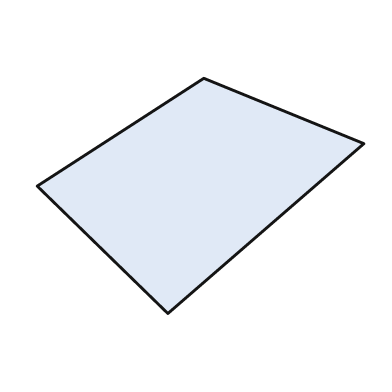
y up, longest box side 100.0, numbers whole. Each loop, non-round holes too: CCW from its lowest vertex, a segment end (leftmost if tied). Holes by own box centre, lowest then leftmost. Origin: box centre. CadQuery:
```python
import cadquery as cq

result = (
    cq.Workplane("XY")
    .moveTo(-10.0, -36.0)
    .lineTo(50.0, 16.0)
    .lineTo(1.0, 36.0)
    .lineTo(-50.0, 3.0)
    .close()
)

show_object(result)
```